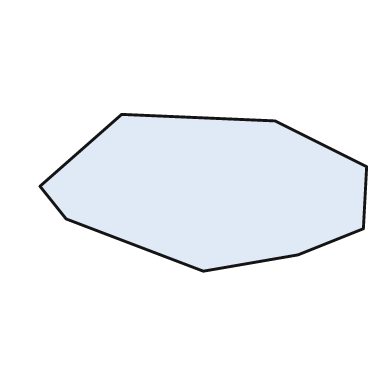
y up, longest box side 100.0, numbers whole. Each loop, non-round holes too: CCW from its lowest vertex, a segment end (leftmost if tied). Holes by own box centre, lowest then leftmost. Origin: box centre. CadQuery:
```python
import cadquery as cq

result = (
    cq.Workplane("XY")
    .moveTo(0.0, -24.0)
    .lineTo(29.0, -19.0)
    .lineTo(49.0, -11.0)
    .lineTo(50.0, 8.0)
    .lineTo(22.0, 22.0)
    .lineTo(-25.0, 24.0)
    .lineTo(-50.0, 2.0)
    .lineTo(-42.0, -8.0)
    .close()
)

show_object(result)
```